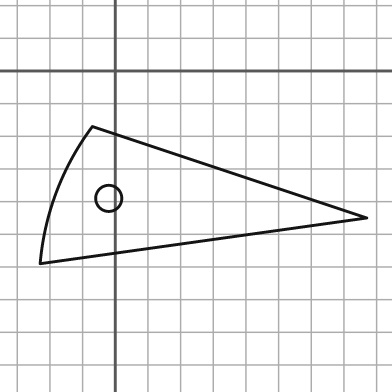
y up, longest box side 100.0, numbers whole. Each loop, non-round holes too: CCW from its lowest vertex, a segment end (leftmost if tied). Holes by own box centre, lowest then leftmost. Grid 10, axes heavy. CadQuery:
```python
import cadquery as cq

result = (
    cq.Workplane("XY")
    .moveTo(-23.0, -59.0)
    .lineTo(77.0, -45.0)
    .lineTo(-7.0, -17.0)
    .threePointArc((-18.0, -37.0), (-23.0, -59.0))
    .close()
    .moveTo(-2.0, -39.0)
    .circle(4.0)
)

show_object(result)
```